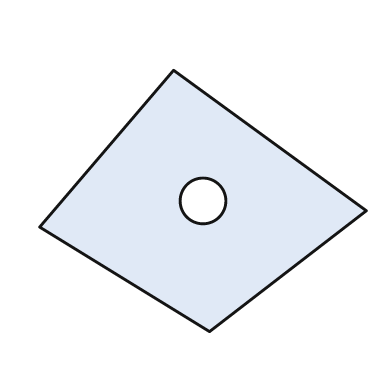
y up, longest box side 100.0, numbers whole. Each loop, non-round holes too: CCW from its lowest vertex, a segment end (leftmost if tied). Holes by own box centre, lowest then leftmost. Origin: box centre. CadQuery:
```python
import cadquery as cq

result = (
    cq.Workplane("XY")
    .moveTo(2.0, -40.0)
    .lineTo(50.0, -3.0)
    .lineTo(-9.0, 40.0)
    .lineTo(-50.0, -8.0)
    .close()
    .moveTo(0.0, 0.0)
    .circle(7.0)
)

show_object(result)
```